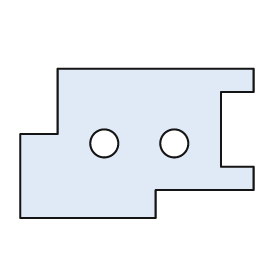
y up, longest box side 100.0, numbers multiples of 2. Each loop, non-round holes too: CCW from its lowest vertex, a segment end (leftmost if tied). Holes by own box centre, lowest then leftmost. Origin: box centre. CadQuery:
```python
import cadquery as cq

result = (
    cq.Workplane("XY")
    .moveTo(-50.0, -32.0)
    .lineTo(8.0, -32.0)
    .lineTo(8.0, -20.0)
    .lineTo(50.0, -20.0)
    .lineTo(50.0, -10.0)
    .lineTo(36.0, -10.0)
    .lineTo(36.0, 22.0)
    .lineTo(50.0, 22.0)
    .lineTo(50.0, 32.0)
    .lineTo(-34.0, 32.0)
    .lineTo(-34.0, 4.0)
    .lineTo(-50.0, 4.0)
    .close()
    .moveTo(-14.0, 0.0)
    .circle(6.0)
    .moveTo(16.0, 0.0)
    .circle(6.0)
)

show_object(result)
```